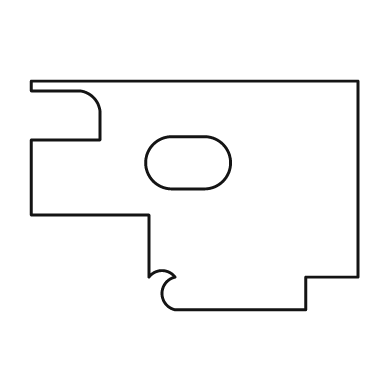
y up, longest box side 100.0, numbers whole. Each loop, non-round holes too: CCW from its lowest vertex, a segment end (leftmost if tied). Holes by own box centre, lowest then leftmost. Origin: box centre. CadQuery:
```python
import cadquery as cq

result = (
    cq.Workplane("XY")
    .moveTo(-6.0, -35.0)
    .lineTo(34.0, -35.0)
    .lineTo(34.0, -25.0)
    .lineTo(50.0, -25.0)
    .lineTo(50.0, 35.0)
    .lineTo(-50.0, 35.0)
    .lineTo(-50.0, 32.0)
    .lineTo(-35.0, 32.0)
    .threePointArc((-31.0, 30.0), (-29.0, 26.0))
    .lineTo(-29.0, 17.0)
    .lineTo(-50.0, 17.0)
    .lineTo(-50.0, -6.0)
    .lineTo(-14.0, -6.0)
    .lineTo(-14.0, -25.0)
    .threePointArc((-10.0, -23.0), (-6.0, -25.0))
    .threePointArc((-10.0, -30.0), (-6.0, -35.0))
    .close()
    .moveTo(-7.0, 2.0)
    .lineTo(3.0, 2.0)
    .threePointArc((11.0, 10.0), (3.0, 18.0))
    .lineTo(-7.0, 18.0)
    .threePointArc((-15.0, 10.0), (-7.0, 2.0))
    .close()
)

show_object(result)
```